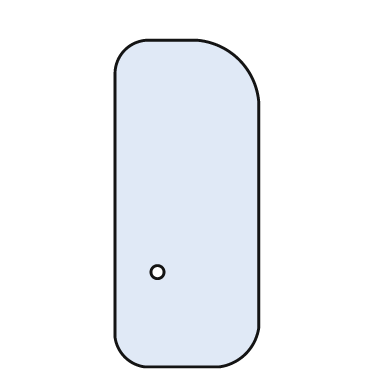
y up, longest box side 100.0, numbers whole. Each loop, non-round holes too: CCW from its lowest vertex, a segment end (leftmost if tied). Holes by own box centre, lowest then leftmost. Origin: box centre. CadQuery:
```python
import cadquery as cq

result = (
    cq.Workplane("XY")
    .moveTo(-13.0, -50.0)
    .lineTo(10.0, -50.0)
    .threePointArc((18.0, -46.0), (22.0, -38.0))
    .lineTo(22.0, 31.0)
    .threePointArc((16.0, 44.0), (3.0, 50.0))
    .lineTo(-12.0, 50.0)
    .threePointArc((-19.0, 47.0), (-22.0, 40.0))
    .lineTo(-22.0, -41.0)
    .threePointArc((-19.0, -47.0), (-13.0, -50.0))
    .close()
    .moveTo(-9.0, -21.0)
    .circle(2.0)
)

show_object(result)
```